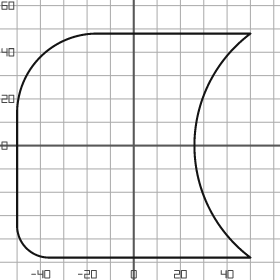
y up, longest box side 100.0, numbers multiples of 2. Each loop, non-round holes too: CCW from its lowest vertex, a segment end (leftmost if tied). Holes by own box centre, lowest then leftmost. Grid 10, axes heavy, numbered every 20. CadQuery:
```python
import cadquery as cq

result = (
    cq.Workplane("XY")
    .moveTo(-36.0, -48.0)
    .lineTo(50.0, -48.0)
    .threePointArc((26.0, 0.0), (50.0, 48.0))
    .lineTo(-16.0, 48.0)
    .threePointArc((-40.0, 38.0), (-50.0, 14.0))
    .lineTo(-50.0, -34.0)
    .threePointArc((-46.0, -44.0), (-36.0, -48.0))
    .close()
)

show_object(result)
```